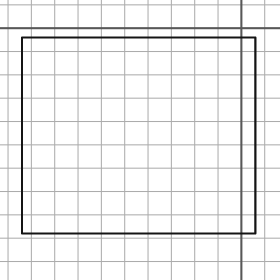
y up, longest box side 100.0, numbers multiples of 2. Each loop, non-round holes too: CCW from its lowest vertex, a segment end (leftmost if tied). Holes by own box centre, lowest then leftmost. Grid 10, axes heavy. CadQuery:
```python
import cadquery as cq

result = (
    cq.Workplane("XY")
    .moveTo(-94.0, -88.0)
    .lineTo(6.0, -88.0)
    .lineTo(6.0, -4.0)
    .lineTo(-94.0, -4.0)
    .close()
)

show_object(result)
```